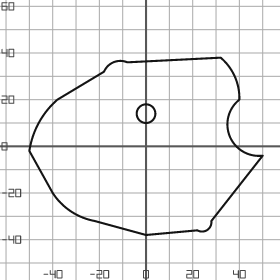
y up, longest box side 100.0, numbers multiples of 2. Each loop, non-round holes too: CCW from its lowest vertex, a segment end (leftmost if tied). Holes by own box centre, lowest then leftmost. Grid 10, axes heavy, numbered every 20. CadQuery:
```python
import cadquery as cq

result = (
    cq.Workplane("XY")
    .moveTo(0.0, -38.0)
    .lineTo(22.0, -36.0)
    .threePointArc((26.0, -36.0), (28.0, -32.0))
    .lineTo(50.0, -4.0)
    .threePointArc((36.0, 4.0), (40.0, 20.0))
    .threePointArc((38.0, 30.0), (32.0, 38.0))
    .lineTo(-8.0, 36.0)
    .threePointArc((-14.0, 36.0), (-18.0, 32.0))
    .lineTo(-38.0, 20.0)
    .threePointArc((-46.0, 10.0), (-50.0, -2.0))
    .lineTo(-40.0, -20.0)
    .threePointArc((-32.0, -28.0), (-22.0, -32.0))
    .close()
    .moveTo(0.0, 14.0)
    .circle(4.0)
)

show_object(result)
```